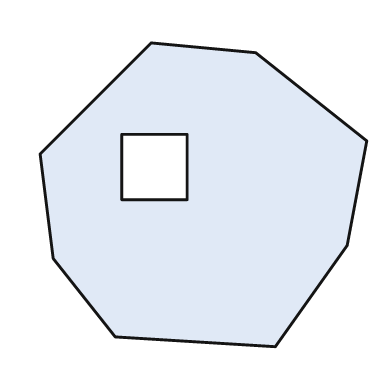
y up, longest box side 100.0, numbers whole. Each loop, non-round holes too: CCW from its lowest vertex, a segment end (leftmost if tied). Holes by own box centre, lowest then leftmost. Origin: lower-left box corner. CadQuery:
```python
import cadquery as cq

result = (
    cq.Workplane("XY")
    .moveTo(72.0, 0.0)
    .lineTo(94.0, 31.0)
    .lineTo(100.0, 63.0)
    .lineTo(66.0, 90.0)
    .lineTo(34.0, 93.0)
    .lineTo(0.0, 59.0)
    .lineTo(4.0, 27.0)
    .lineTo(23.0, 3.0)
    .close()
    .moveTo(25.0, 45.0)
    .lineTo(45.0, 45.0)
    .lineTo(45.0, 65.0)
    .lineTo(25.0, 65.0)
    .close()
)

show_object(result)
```